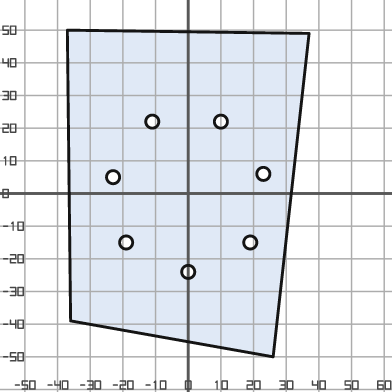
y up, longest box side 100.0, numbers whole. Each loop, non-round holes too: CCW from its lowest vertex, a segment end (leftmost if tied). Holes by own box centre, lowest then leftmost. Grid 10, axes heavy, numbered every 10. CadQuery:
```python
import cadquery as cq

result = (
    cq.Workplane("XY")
    .moveTo(26.0, -50.0)
    .lineTo(37.0, 49.0)
    .lineTo(-37.0, 50.0)
    .lineTo(-36.0, -39.0)
    .close()
    .moveTo(0.0, -24.0)
    .circle(2.0)
    .moveTo(-19.0, -15.0)
    .circle(2.0)
    .moveTo(19.0, -15.0)
    .circle(2.0)
    .moveTo(-23.0, 5.0)
    .circle(2.0)
    .moveTo(23.0, 6.0)
    .circle(2.0)
    .moveTo(-11.0, 22.0)
    .circle(2.0)
    .moveTo(10.0, 22.0)
    .circle(2.0)
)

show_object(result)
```